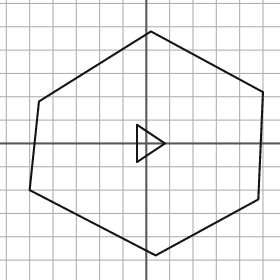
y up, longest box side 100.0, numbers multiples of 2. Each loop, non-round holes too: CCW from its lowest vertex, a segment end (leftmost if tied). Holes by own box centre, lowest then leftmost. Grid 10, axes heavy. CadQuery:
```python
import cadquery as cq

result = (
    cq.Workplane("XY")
    .moveTo(4.0, -48.0)
    .lineTo(48.0, -24.0)
    .lineTo(50.0, 22.0)
    .lineTo(2.0, 48.0)
    .lineTo(-46.0, 18.0)
    .lineTo(-50.0, -20.0)
    .close()
    .moveTo(-4.0, -8.0)
    .lineTo(8.0, 0.0)
    .lineTo(-4.0, 8.0)
    .close()
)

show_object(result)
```